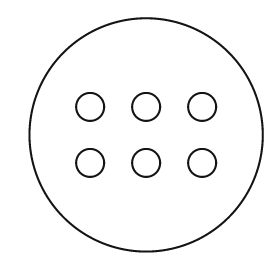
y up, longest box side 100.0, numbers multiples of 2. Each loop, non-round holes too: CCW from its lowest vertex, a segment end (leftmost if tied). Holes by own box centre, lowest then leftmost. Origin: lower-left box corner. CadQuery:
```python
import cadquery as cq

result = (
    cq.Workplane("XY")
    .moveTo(50.0, 50.0)
    .circle(50.0)
    .moveTo(26.0, 38.0)
    .circle(6.0)
    .moveTo(50.0, 38.0)
    .circle(6.0)
    .moveTo(74.0, 38.0)
    .circle(6.0)
    .moveTo(26.0, 62.0)
    .circle(6.0)
    .moveTo(50.0, 62.0)
    .circle(6.0)
    .moveTo(74.0, 62.0)
    .circle(6.0)
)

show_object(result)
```